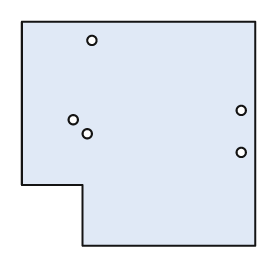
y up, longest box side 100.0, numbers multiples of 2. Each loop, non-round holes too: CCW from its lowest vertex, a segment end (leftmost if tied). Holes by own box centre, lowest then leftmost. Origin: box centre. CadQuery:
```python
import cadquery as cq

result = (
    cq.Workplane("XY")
    .moveTo(-24.0, -48.0)
    .lineTo(50.0, -48.0)
    .lineTo(50.0, 48.0)
    .lineTo(-50.0, 48.0)
    .lineTo(-50.0, -22.0)
    .lineTo(-24.0, -22.0)
    .close()
    .moveTo(44.0, -8.0)
    .circle(2.0)
    .moveTo(-22.0, 0.0)
    .circle(2.0)
    .moveTo(-28.0, 6.0)
    .circle(2.0)
    .moveTo(44.0, 10.0)
    .circle(2.0)
    .moveTo(-20.0, 40.0)
    .circle(2.0)
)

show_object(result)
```